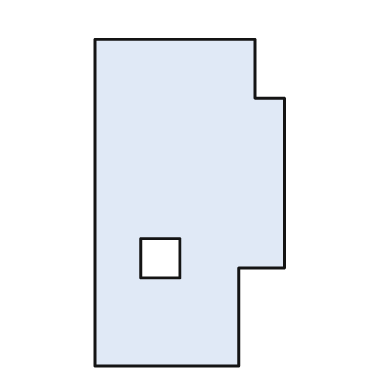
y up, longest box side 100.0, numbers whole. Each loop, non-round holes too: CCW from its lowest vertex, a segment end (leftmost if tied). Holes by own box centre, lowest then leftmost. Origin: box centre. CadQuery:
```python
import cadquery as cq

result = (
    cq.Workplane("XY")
    .moveTo(-29.0, -50.0)
    .lineTo(15.0, -50.0)
    .lineTo(15.0, -20.0)
    .lineTo(29.0, -20.0)
    .lineTo(29.0, 32.0)
    .lineTo(20.0, 32.0)
    .lineTo(20.0, 50.0)
    .lineTo(-29.0, 50.0)
    .close()
    .moveTo(-15.0, -23.0)
    .lineTo(-3.0, -23.0)
    .lineTo(-3.0, -11.0)
    .lineTo(-15.0, -11.0)
    .close()
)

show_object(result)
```